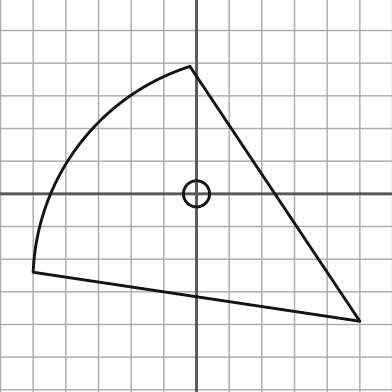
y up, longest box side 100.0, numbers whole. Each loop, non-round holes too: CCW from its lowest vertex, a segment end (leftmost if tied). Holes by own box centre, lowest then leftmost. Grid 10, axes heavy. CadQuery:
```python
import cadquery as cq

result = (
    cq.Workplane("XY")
    .moveTo(50.0, -39.0)
    .lineTo(-2.0, 39.0)
    .threePointArc((-36.0, 15.0), (-50.0, -24.0))
    .close()
    .moveTo(0.0, 0.0)
    .circle(4.0)
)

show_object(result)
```